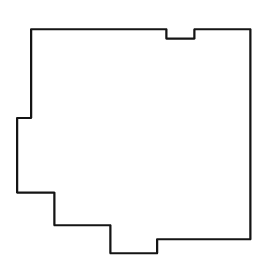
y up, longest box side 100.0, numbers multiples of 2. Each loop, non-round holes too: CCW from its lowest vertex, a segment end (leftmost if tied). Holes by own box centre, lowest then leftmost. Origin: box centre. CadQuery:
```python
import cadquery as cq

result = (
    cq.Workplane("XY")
    .moveTo(-10.0, -48.0)
    .lineTo(10.0, -48.0)
    .lineTo(10.0, -42.0)
    .lineTo(50.0, -42.0)
    .lineTo(50.0, 48.0)
    .lineTo(26.0, 48.0)
    .lineTo(26.0, 44.0)
    .lineTo(14.0, 44.0)
    .lineTo(14.0, 48.0)
    .lineTo(-44.0, 48.0)
    .lineTo(-44.0, 10.0)
    .lineTo(-50.0, 10.0)
    .lineTo(-50.0, -22.0)
    .lineTo(-34.0, -22.0)
    .lineTo(-34.0, -36.0)
    .lineTo(-10.0, -36.0)
    .close()
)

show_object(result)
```